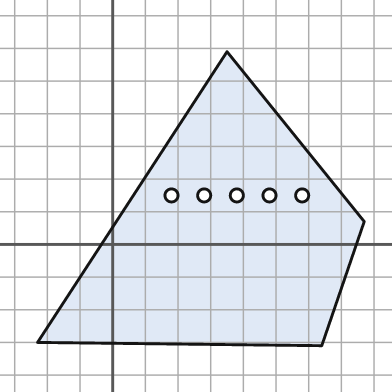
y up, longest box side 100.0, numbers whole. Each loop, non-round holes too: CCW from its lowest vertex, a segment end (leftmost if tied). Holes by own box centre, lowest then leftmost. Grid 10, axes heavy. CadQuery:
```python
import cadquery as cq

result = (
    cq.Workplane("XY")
    .moveTo(64.0, -31.0)
    .lineTo(77.0, 7.0)
    .lineTo(35.0, 59.0)
    .lineTo(-23.0, -30.0)
    .close()
    .moveTo(18.0, 15.0)
    .circle(2.0)
    .moveTo(28.0, 15.0)
    .circle(2.0)
    .moveTo(38.0, 15.0)
    .circle(2.0)
    .moveTo(48.0, 15.0)
    .circle(2.0)
    .moveTo(58.0, 15.0)
    .circle(2.0)
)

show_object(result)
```